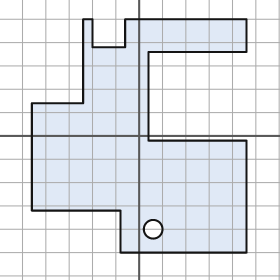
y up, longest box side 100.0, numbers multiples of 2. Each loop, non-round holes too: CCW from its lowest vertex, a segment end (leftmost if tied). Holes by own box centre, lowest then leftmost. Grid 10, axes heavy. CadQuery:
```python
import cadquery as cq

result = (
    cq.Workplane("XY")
    .moveTo(-8.0, -50.0)
    .lineTo(46.0, -50.0)
    .lineTo(46.0, -2.0)
    .lineTo(4.0, -2.0)
    .lineTo(4.0, 36.0)
    .lineTo(46.0, 36.0)
    .lineTo(46.0, 50.0)
    .lineTo(-6.0, 50.0)
    .lineTo(-6.0, 38.0)
    .lineTo(-20.0, 38.0)
    .lineTo(-20.0, 50.0)
    .lineTo(-24.0, 50.0)
    .lineTo(-24.0, 14.0)
    .lineTo(-46.0, 14.0)
    .lineTo(-46.0, -32.0)
    .lineTo(-8.0, -32.0)
    .close()
    .moveTo(6.0, -40.0)
    .circle(4.0)
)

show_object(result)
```